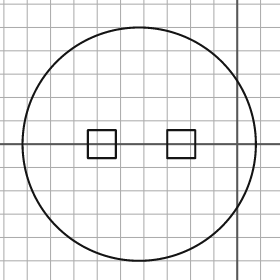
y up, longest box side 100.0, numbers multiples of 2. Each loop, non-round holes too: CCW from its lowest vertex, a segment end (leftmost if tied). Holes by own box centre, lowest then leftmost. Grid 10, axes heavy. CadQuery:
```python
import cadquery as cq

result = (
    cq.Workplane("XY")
    .moveTo(-42.0, 0.0)
    .circle(50.0)
    .moveTo(-64.0, -6.0)
    .lineTo(-52.0, -6.0)
    .lineTo(-52.0, 6.0)
    .lineTo(-64.0, 6.0)
    .close()
    .moveTo(-30.0, -6.0)
    .lineTo(-18.0, -6.0)
    .lineTo(-18.0, 6.0)
    .lineTo(-30.0, 6.0)
    .close()
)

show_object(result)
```